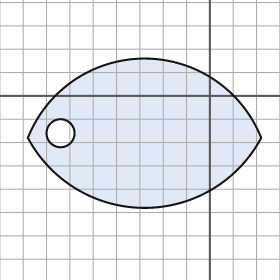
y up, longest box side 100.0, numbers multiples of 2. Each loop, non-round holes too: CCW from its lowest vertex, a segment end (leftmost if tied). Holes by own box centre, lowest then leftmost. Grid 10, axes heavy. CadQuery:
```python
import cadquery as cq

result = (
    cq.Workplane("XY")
    .moveTo(-78.0, -18.0)
    .threePointArc((-28.0, -48.0), (22.0, -18.0))
    .threePointArc((-28.0, 16.0), (-78.0, -18.0))
    .close()
    .moveTo(-64.0, -16.0)
    .circle(6.0)
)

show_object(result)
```